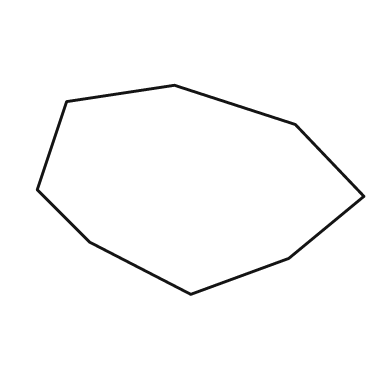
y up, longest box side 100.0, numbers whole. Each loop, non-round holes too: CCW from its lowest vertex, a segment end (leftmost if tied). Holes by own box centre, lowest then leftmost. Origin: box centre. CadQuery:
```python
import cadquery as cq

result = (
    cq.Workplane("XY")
    .moveTo(-3.0, -32.0)
    .lineTo(27.0, -21.0)
    .lineTo(50.0, -2.0)
    .lineTo(29.0, 20.0)
    .lineTo(-8.0, 32.0)
    .lineTo(-41.0, 27.0)
    .lineTo(-50.0, 0.0)
    .lineTo(-34.0, -16.0)
    .close()
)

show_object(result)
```